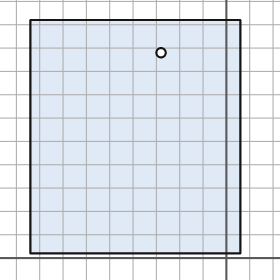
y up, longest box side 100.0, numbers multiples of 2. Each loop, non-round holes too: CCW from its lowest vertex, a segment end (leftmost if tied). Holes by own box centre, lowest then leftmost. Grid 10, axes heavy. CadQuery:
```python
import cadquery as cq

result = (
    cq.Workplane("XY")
    .moveTo(-84.0, 2.0)
    .lineTo(6.0, 2.0)
    .lineTo(6.0, 102.0)
    .lineTo(-84.0, 102.0)
    .close()
    .moveTo(-28.0, 88.0)
    .circle(2.0)
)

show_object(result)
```